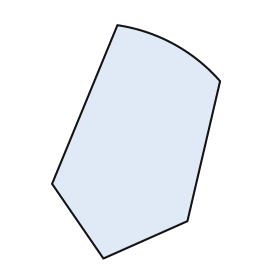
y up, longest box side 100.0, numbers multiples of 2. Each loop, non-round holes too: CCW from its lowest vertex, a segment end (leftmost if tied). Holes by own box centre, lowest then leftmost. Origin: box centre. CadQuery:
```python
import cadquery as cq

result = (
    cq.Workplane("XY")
    .moveTo(-14.0, -50.0)
    .lineTo(22.0, -34.0)
    .lineTo(36.0, 26.0)
    .threePointArc((16.0, 42.0), (-8.0, 50.0))
    .lineTo(-36.0, -18.0)
    .close()
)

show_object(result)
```